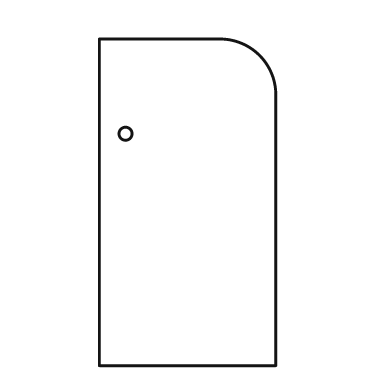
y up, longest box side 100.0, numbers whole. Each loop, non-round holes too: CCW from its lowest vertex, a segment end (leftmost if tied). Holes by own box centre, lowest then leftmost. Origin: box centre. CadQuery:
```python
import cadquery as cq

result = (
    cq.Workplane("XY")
    .moveTo(-27.0, -50.0)
    .lineTo(27.0, -50.0)
    .lineTo(27.0, 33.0)
    .threePointArc((22.0, 45.0), (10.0, 50.0))
    .lineTo(-27.0, 50.0)
    .close()
    .moveTo(-19.0, 21.0)
    .circle(2.0)
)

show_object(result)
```